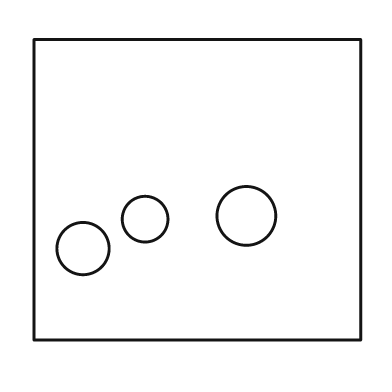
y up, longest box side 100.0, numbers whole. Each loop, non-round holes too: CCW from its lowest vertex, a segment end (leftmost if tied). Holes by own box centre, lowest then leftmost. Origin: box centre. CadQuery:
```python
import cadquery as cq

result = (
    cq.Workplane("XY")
    .moveTo(-50.0, -46.0)
    .lineTo(50.0, -46.0)
    .lineTo(50.0, 46.0)
    .lineTo(-50.0, 46.0)
    .close()
    .moveTo(-35.0, -18.0)
    .circle(8.0)
    .moveTo(-16.0, -9.0)
    .circle(7.0)
    .moveTo(15.0, -8.0)
    .circle(9.0)
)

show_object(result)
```